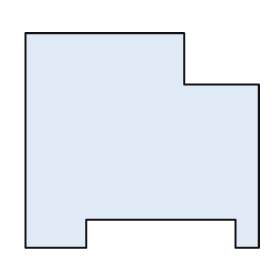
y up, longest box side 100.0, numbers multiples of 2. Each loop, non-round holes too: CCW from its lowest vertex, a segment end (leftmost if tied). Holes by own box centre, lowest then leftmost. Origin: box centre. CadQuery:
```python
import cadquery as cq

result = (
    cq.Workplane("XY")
    .moveTo(-50.0, -46.0)
    .lineTo(-24.0, -46.0)
    .lineTo(-24.0, -34.0)
    .lineTo(40.0, -34.0)
    .lineTo(40.0, -46.0)
    .lineTo(50.0, -46.0)
    .lineTo(50.0, 24.0)
    .lineTo(18.0, 24.0)
    .lineTo(18.0, 46.0)
    .lineTo(-50.0, 46.0)
    .close()
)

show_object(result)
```